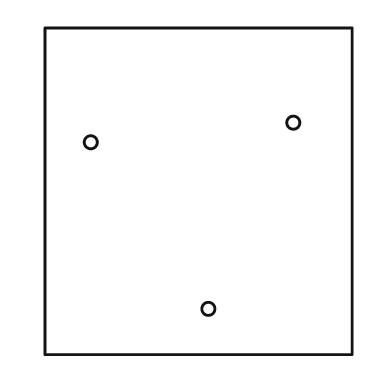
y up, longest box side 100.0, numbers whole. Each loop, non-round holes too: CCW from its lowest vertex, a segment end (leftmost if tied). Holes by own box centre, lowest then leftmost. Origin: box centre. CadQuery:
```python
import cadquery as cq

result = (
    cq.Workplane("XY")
    .moveTo(-47.0, -50.0)
    .lineTo(47.0, -50.0)
    .lineTo(47.0, 50.0)
    .lineTo(-47.0, 50.0)
    .close()
    .moveTo(3.0, -36.0)
    .circle(2.0)
    .moveTo(-33.0, 15.0)
    .circle(2.0)
    .moveTo(29.0, 21.0)
    .circle(2.0)
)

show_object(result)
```